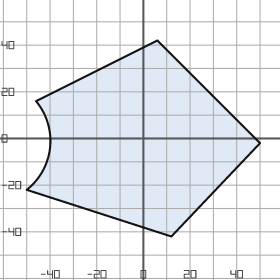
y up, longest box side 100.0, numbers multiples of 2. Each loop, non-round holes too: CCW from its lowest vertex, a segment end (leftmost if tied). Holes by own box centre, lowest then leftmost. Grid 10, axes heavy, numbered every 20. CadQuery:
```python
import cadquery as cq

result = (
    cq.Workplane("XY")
    .moveTo(12.0, -42.0)
    .lineTo(50.0, -2.0)
    .lineTo(6.0, 42.0)
    .lineTo(-46.0, 16.0)
    .threePointArc((-40.0, -4.0), (-50.0, -22.0))
    .close()
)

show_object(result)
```